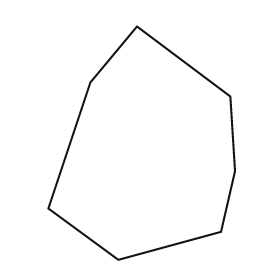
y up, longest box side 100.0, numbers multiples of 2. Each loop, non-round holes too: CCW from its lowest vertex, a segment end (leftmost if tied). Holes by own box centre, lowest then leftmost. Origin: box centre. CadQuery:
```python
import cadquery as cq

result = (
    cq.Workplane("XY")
    .moveTo(-10.0, -50.0)
    .lineTo(34.0, -38.0)
    .lineTo(40.0, -12.0)
    .lineTo(38.0, 20.0)
    .lineTo(-2.0, 50.0)
    .lineTo(-22.0, 26.0)
    .lineTo(-40.0, -28.0)
    .close()
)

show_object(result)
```